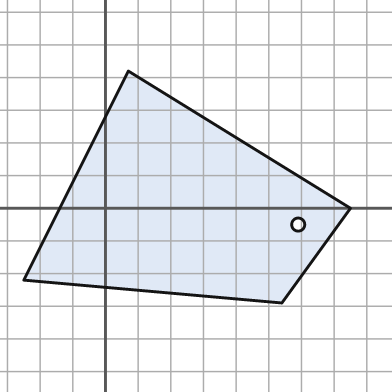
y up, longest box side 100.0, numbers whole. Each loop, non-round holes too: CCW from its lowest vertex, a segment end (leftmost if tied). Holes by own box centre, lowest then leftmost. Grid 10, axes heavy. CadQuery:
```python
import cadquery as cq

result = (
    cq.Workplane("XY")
    .moveTo(54.0, -29.0)
    .lineTo(75.0, 0.0)
    .lineTo(7.0, 42.0)
    .lineTo(-25.0, -22.0)
    .close()
    .moveTo(59.0, -5.0)
    .circle(2.0)
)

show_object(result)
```